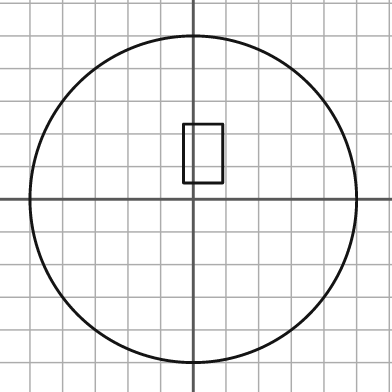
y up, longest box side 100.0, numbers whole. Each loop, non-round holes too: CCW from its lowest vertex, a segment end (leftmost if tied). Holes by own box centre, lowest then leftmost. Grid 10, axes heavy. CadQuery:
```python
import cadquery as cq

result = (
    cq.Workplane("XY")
    .moveTo(0.0, 0.0)
    .circle(50.0)
    .moveTo(-3.0, 5.0)
    .lineTo(9.0, 5.0)
    .lineTo(9.0, 23.0)
    .lineTo(-3.0, 23.0)
    .close()
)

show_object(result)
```